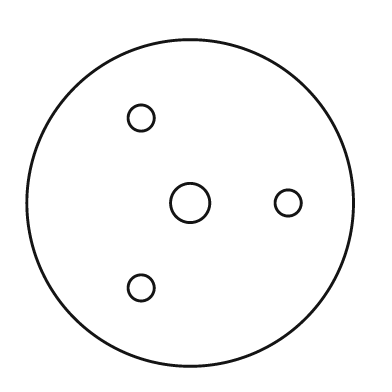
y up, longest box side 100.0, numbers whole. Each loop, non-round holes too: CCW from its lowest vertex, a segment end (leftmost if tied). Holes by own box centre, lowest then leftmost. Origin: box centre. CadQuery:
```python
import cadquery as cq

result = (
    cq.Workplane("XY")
    .moveTo(0.0, 0.0)
    .circle(50.0)
    .moveTo(-15.0, -26.0)
    .circle(4.0)
    .moveTo(0.0, 0.0)
    .circle(6.0)
    .moveTo(30.0, 0.0)
    .circle(4.0)
    .moveTo(-15.0, 26.0)
    .circle(4.0)
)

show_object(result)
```